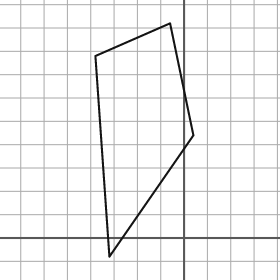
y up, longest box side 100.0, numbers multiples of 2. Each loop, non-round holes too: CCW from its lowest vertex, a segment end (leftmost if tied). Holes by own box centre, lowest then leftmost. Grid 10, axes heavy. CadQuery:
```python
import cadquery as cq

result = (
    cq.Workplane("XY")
    .moveTo(-32.0, -8.0)
    .lineTo(4.0, 44.0)
    .lineTo(-6.0, 92.0)
    .lineTo(-38.0, 78.0)
    .close()
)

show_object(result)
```